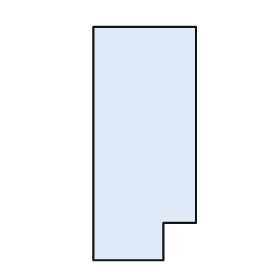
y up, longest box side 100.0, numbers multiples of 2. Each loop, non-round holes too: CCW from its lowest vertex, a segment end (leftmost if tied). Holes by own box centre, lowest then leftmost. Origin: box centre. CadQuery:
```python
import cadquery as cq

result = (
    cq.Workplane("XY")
    .moveTo(-22.0, -50.0)
    .lineTo(8.0, -50.0)
    .lineTo(8.0, -34.0)
    .lineTo(22.0, -34.0)
    .lineTo(22.0, 50.0)
    .lineTo(-22.0, 50.0)
    .close()
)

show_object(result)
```